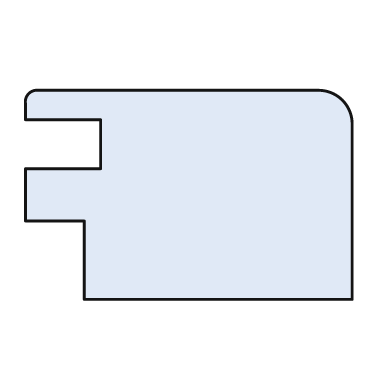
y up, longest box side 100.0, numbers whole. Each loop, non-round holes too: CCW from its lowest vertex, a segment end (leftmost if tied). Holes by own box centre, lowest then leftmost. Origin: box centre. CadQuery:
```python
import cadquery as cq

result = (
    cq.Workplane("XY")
    .moveTo(-32.0, -32.0)
    .lineTo(50.0, -32.0)
    .lineTo(50.0, 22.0)
    .threePointArc((47.0, 29.0), (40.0, 32.0))
    .lineTo(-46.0, 32.0)
    .threePointArc((-49.0, 31.0), (-50.0, 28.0))
    .lineTo(-50.0, 23.0)
    .lineTo(-27.0, 23.0)
    .lineTo(-27.0, 8.0)
    .lineTo(-50.0, 8.0)
    .lineTo(-50.0, -8.0)
    .lineTo(-32.0, -8.0)
    .close()
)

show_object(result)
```